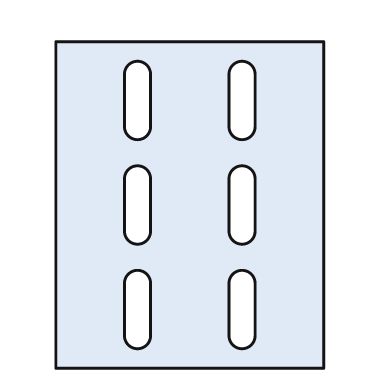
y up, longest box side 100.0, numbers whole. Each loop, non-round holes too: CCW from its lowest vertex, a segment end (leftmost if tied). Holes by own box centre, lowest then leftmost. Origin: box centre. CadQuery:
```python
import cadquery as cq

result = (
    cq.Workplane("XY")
    .moveTo(-41.0, -50.0)
    .lineTo(41.0, -50.0)
    .lineTo(41.0, 50.0)
    .lineTo(-41.0, 50.0)
    .close()
    .moveTo(-20.0, -40.0)
    .threePointArc((-16.0, -44.0), (-12.0, -40.0))
    .lineTo(-12.0, -24.0)
    .threePointArc((-16.0, -20.0), (-20.0, -24.0))
    .close()
    .moveTo(12.0, -40.0)
    .threePointArc((16.0, -44.0), (20.0, -40.0))
    .lineTo(20.0, -24.0)
    .threePointArc((16.0, -20.0), (12.0, -24.0))
    .close()
    .moveTo(-20.0, -8.0)
    .threePointArc((-16.0, -12.0), (-12.0, -8.0))
    .lineTo(-12.0, 8.0)
    .threePointArc((-16.0, 12.0), (-20.0, 8.0))
    .close()
    .moveTo(12.0, -8.0)
    .threePointArc((16.0, -12.0), (20.0, -8.0))
    .lineTo(20.0, 8.0)
    .threePointArc((16.0, 12.0), (12.0, 8.0))
    .close()
    .moveTo(-20.0, 24.0)
    .threePointArc((-16.0, 20.0), (-12.0, 24.0))
    .lineTo(-12.0, 40.0)
    .threePointArc((-16.0, 44.0), (-20.0, 40.0))
    .close()
    .moveTo(12.0, 24.0)
    .threePointArc((16.0, 20.0), (20.0, 24.0))
    .lineTo(20.0, 40.0)
    .threePointArc((16.0, 44.0), (12.0, 40.0))
    .close()
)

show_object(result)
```